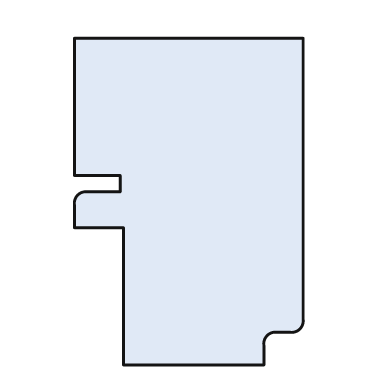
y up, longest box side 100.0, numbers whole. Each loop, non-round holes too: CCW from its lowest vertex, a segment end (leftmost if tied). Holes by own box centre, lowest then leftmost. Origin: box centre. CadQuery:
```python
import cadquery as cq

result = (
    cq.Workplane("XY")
    .moveTo(-20.0, -50.0)
    .lineTo(23.0, -50.0)
    .lineTo(23.0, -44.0)
    .threePointArc((24.0, -41.0), (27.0, -40.0))
    .lineTo(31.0, -40.0)
    .threePointArc((34.0, -39.0), (35.0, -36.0))
    .lineTo(35.0, 50.0)
    .lineTo(-35.0, 50.0)
    .lineTo(-35.0, 8.0)
    .lineTo(-21.0, 8.0)
    .lineTo(-21.0, 3.0)
    .lineTo(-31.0, 3.0)
    .threePointArc((-34.0, 2.0), (-35.0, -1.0))
    .lineTo(-35.0, -8.0)
    .lineTo(-20.0, -8.0)
    .close()
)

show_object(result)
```